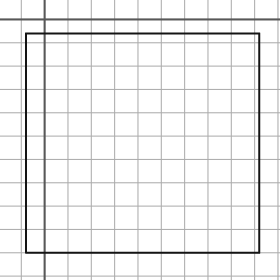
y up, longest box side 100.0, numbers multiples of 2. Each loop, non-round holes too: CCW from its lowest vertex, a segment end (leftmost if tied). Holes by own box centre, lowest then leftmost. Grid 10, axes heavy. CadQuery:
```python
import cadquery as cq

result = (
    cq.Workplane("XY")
    .moveTo(-8.0, -100.0)
    .lineTo(92.0, -100.0)
    .lineTo(92.0, -6.0)
    .lineTo(-8.0, -6.0)
    .close()
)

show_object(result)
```